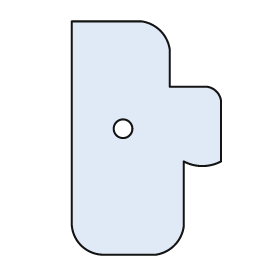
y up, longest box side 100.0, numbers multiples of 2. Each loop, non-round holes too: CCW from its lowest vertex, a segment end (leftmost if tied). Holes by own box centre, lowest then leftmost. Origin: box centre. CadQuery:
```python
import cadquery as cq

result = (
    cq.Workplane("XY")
    .moveTo(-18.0, -50.0)
    .lineTo(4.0, -50.0)
    .threePointArc((12.0, -46.0), (16.0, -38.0))
    .lineTo(16.0, -10.0)
    .threePointArc((24.0, -12.0), (32.0, -10.0))
    .lineTo(32.0, 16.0)
    .threePointArc((30.0, 20.0), (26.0, 22.0))
    .lineTo(10.0, 22.0)
    .lineTo(10.0, 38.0)
    .threePointArc((6.0, 46.0), (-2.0, 50.0))
    .lineTo(-32.0, 50.0)
    .lineTo(-32.0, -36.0)
    .threePointArc((-28.0, -46.0), (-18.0, -50.0))
    .close()
    .moveTo(-10.0, 4.0)
    .circle(4.0)
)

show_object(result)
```